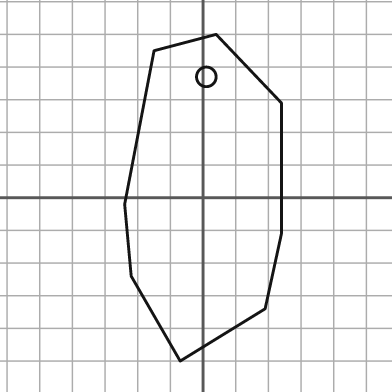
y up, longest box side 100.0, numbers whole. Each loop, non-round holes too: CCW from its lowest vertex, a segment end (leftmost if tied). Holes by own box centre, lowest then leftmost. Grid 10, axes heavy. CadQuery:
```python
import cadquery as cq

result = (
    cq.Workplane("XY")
    .moveTo(-7.0, -50.0)
    .lineTo(19.0, -34.0)
    .lineTo(24.0, -11.0)
    .lineTo(24.0, 29.0)
    .lineTo(4.0, 50.0)
    .lineTo(-15.0, 45.0)
    .lineTo(-24.0, -2.0)
    .lineTo(-22.0, -24.0)
    .close()
    .moveTo(1.0, 37.0)
    .circle(3.0)
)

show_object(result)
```